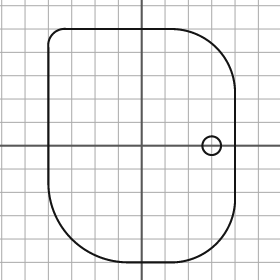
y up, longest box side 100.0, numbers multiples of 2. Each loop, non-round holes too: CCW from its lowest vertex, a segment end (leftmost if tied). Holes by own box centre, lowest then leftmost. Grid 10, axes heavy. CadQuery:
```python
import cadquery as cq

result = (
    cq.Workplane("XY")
    .moveTo(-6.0, -50.0)
    .lineTo(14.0, -50.0)
    .threePointArc((32.0, -42.0), (40.0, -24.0))
    .lineTo(40.0, 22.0)
    .threePointArc((32.0, 42.0), (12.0, 50.0))
    .lineTo(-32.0, 50.0)
    .threePointArc((-38.0, 48.0), (-40.0, 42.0))
    .lineTo(-40.0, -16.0)
    .threePointArc((-30.0, -40.0), (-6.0, -50.0))
    .close()
    .moveTo(30.0, 0.0)
    .circle(4.0)
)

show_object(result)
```